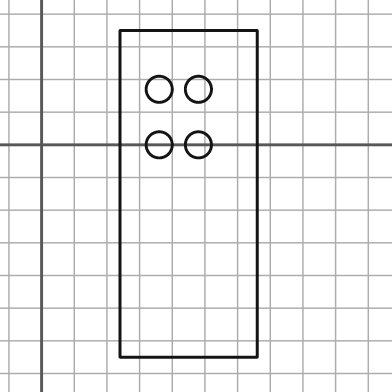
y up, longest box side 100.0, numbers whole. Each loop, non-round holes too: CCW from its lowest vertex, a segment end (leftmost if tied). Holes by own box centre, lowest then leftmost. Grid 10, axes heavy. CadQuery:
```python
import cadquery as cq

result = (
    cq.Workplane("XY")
    .moveTo(24.0, -65.0)
    .lineTo(66.0, -65.0)
    .lineTo(66.0, 35.0)
    .lineTo(24.0, 35.0)
    .close()
    .moveTo(36.0, 0.0)
    .circle(4.0)
    .moveTo(48.0, 0.0)
    .circle(4.0)
    .moveTo(36.0, 17.0)
    .circle(4.0)
    .moveTo(48.0, 17.0)
    .circle(4.0)
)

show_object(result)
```